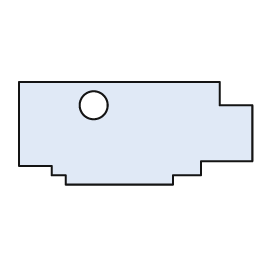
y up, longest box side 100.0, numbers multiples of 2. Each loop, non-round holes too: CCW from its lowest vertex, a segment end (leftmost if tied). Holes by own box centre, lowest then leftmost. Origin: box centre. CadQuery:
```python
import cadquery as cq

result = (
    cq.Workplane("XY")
    .moveTo(-30.0, -22.0)
    .lineTo(16.0, -22.0)
    .lineTo(16.0, -18.0)
    .lineTo(28.0, -18.0)
    .lineTo(28.0, -12.0)
    .lineTo(50.0, -12.0)
    .lineTo(50.0, 12.0)
    .lineTo(36.0, 12.0)
    .lineTo(36.0, 22.0)
    .lineTo(-50.0, 22.0)
    .lineTo(-50.0, -14.0)
    .lineTo(-36.0, -14.0)
    .lineTo(-36.0, -18.0)
    .lineTo(-30.0, -18.0)
    .close()
    .moveTo(-18.0, 12.0)
    .circle(6.0)
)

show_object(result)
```